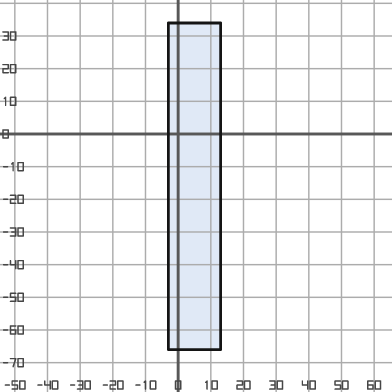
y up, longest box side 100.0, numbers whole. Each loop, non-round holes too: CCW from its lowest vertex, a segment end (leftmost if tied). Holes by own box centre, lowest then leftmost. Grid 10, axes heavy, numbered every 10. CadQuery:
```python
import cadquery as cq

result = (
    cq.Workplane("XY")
    .moveTo(-3.0, -66.0)
    .lineTo(13.0, -66.0)
    .lineTo(13.0, 34.0)
    .lineTo(-3.0, 34.0)
    .close()
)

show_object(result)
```